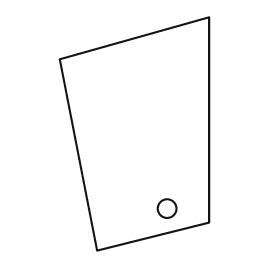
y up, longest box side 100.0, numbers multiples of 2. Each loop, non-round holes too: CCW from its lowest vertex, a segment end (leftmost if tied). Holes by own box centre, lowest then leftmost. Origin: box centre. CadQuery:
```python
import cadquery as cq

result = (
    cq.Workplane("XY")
    .moveTo(-16.0, -50.0)
    .lineTo(32.0, -38.0)
    .lineTo(32.0, 50.0)
    .lineTo(-32.0, 32.0)
    .close()
    .moveTo(14.0, -32.0)
    .circle(4.0)
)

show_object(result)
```